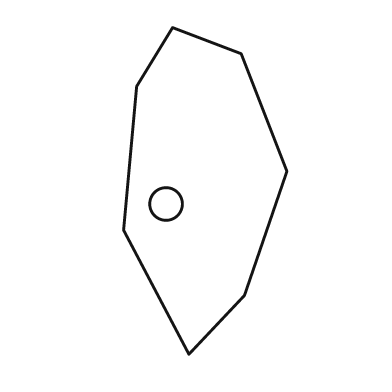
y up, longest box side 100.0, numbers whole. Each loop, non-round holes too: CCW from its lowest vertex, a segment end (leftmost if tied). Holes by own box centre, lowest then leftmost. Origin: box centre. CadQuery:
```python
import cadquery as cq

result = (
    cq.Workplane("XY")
    .moveTo(-5.0, -50.0)
    .lineTo(12.0, -32.0)
    .lineTo(25.0, 6.0)
    .lineTo(11.0, 42.0)
    .lineTo(-10.0, 50.0)
    .lineTo(-21.0, 32.0)
    .lineTo(-25.0, -12.0)
    .close()
    .moveTo(-12.0, -4.0)
    .circle(5.0)
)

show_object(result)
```